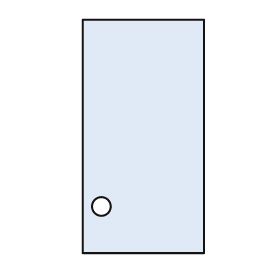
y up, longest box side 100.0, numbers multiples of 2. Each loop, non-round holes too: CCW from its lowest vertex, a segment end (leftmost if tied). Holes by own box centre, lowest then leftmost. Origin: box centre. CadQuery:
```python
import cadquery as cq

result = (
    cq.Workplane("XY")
    .moveTo(-26.0, -50.0)
    .lineTo(26.0, -50.0)
    .lineTo(26.0, 50.0)
    .lineTo(-26.0, 50.0)
    .close()
    .moveTo(-18.0, -30.0)
    .circle(4.0)
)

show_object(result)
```